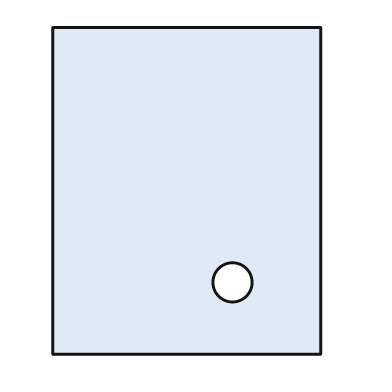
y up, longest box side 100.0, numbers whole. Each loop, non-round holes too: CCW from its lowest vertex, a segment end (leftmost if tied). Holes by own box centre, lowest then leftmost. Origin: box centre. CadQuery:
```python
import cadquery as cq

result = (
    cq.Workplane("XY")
    .moveTo(-41.0, -50.0)
    .lineTo(41.0, -50.0)
    .lineTo(41.0, 50.0)
    .lineTo(-41.0, 50.0)
    .close()
    .moveTo(14.0, -28.0)
    .circle(6.0)
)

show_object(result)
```